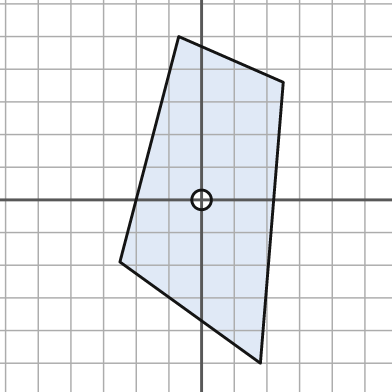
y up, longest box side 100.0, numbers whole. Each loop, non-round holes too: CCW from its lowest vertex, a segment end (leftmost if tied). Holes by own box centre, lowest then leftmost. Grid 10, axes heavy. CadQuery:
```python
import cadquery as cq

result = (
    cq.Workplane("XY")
    .moveTo(18.0, -50.0)
    .lineTo(25.0, 36.0)
    .lineTo(-7.0, 50.0)
    .lineTo(-25.0, -19.0)
    .close()
    .moveTo(0.0, 0.0)
    .circle(3.0)
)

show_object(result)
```